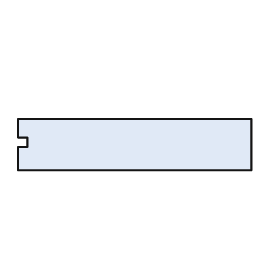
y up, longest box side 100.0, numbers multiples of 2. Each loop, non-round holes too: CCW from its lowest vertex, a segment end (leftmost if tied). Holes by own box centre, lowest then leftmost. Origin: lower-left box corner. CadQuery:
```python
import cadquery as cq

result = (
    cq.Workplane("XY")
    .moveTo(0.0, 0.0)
    .lineTo(100.0, 0.0)
    .lineTo(100.0, 22.0)
    .lineTo(0.0, 22.0)
    .lineTo(0.0, 14.0)
    .lineTo(4.0, 14.0)
    .lineTo(4.0, 10.0)
    .lineTo(0.0, 10.0)
    .close()
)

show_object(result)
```